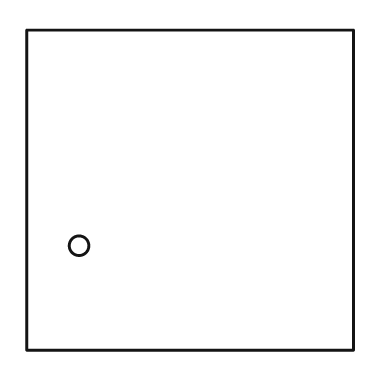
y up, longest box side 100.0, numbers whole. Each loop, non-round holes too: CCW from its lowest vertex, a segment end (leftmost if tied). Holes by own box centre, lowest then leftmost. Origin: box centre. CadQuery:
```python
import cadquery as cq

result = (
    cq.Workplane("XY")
    .moveTo(-50.0, -49.0)
    .lineTo(50.0, -49.0)
    .lineTo(50.0, 49.0)
    .lineTo(-50.0, 49.0)
    .close()
    .moveTo(-34.0, -17.0)
    .circle(3.0)
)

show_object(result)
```